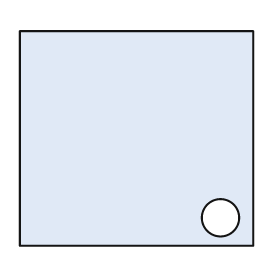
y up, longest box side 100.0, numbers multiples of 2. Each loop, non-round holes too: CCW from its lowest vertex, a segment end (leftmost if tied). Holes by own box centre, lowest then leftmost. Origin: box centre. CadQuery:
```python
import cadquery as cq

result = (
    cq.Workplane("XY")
    .moveTo(-50.0, -46.0)
    .lineTo(50.0, -46.0)
    .lineTo(50.0, 46.0)
    .lineTo(-50.0, 46.0)
    .close()
    .moveTo(36.0, -34.0)
    .circle(8.0)
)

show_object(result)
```